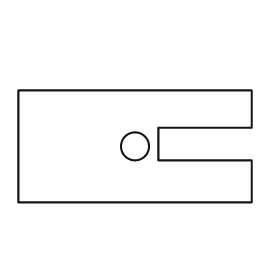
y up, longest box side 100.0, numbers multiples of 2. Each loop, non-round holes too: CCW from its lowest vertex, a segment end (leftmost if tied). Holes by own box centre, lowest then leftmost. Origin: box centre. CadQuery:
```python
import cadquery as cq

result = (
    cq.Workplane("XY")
    .moveTo(-50.0, -24.0)
    .lineTo(50.0, -24.0)
    .lineTo(50.0, -6.0)
    .lineTo(10.0, -6.0)
    .lineTo(10.0, 8.0)
    .lineTo(50.0, 8.0)
    .lineTo(50.0, 24.0)
    .lineTo(-50.0, 24.0)
    .close()
    .moveTo(0.0, 0.0)
    .circle(6.0)
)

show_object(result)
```